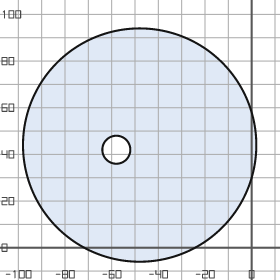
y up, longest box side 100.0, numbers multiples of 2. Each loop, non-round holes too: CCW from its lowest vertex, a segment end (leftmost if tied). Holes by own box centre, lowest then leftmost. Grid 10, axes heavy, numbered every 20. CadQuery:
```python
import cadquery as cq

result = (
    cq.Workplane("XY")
    .moveTo(-48.0, 44.0)
    .circle(50.0)
    .moveTo(-58.0, 42.0)
    .circle(6.0)
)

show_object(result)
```